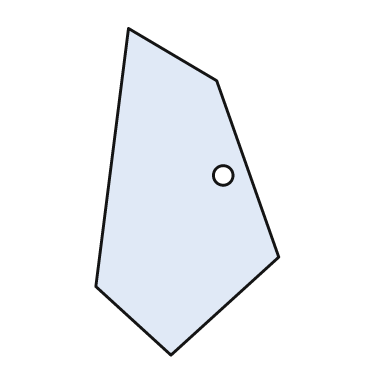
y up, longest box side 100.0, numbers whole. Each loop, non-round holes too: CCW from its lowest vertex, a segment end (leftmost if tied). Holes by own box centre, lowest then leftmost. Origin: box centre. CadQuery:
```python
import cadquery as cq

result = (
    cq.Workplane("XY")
    .moveTo(-5.0, -50.0)
    .lineTo(28.0, -20.0)
    .lineTo(9.0, 34.0)
    .lineTo(-18.0, 50.0)
    .lineTo(-28.0, -29.0)
    .close()
    .moveTo(11.0, 5.0)
    .circle(3.0)
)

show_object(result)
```